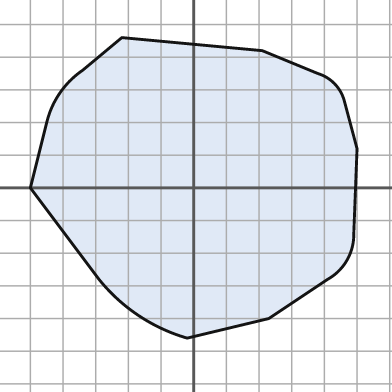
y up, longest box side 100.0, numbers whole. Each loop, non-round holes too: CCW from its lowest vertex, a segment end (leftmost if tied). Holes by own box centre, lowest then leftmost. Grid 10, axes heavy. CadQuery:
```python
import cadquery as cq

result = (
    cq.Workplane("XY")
    .moveTo(-2.0, -46.0)
    .lineTo(23.0, -40.0)
    .lineTo(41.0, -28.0)
    .threePointArc((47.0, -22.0), (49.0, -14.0))
    .lineTo(50.0, 12.0)
    .lineTo(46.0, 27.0)
    .threePointArc((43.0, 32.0), (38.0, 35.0))
    .lineTo(21.0, 42.0)
    .lineTo(-22.0, 46.0)
    .lineTo(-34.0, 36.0)
    .threePointArc((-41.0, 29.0), (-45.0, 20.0))
    .lineTo(-50.0, 0.0)
    .lineTo(-29.0, -28.0)
    .threePointArc((-17.0, -39.0), (-2.0, -46.0))
    .close()
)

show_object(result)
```